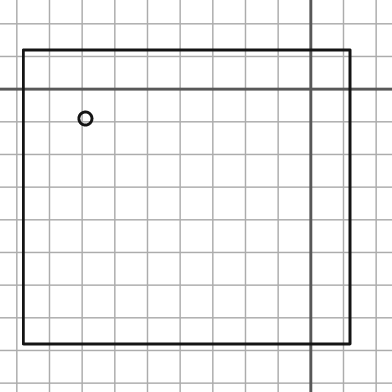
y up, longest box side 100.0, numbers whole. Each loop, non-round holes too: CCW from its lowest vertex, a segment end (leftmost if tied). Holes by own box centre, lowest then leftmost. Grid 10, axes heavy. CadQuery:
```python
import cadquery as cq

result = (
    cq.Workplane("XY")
    .moveTo(-88.0, -78.0)
    .lineTo(12.0, -78.0)
    .lineTo(12.0, 12.0)
    .lineTo(-88.0, 12.0)
    .close()
    .moveTo(-69.0, -9.0)
    .circle(2.0)
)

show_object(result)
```